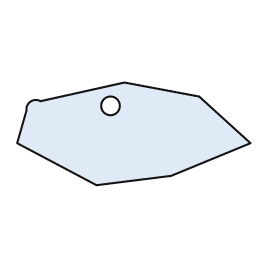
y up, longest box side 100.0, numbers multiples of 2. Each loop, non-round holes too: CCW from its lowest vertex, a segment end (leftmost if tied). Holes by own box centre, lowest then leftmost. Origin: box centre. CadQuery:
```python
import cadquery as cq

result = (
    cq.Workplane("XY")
    .moveTo(-16.0, -22.0)
    .lineTo(16.0, -18.0)
    .lineTo(50.0, -4.0)
    .lineTo(28.0, 16.0)
    .lineTo(-4.0, 22.0)
    .lineTo(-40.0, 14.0)
    .threePointArc((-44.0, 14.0), (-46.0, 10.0))
    .lineTo(-50.0, -4.0)
    .close()
    .moveTo(-10.0, 12.0)
    .circle(4.0)
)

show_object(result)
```